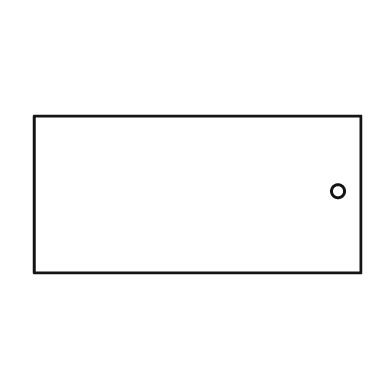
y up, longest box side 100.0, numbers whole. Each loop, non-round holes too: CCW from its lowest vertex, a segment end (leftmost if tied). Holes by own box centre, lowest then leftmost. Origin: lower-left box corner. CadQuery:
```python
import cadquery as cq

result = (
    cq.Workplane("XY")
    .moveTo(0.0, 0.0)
    .lineTo(100.0, 0.0)
    .lineTo(100.0, 48.0)
    .lineTo(0.0, 48.0)
    .close()
    .moveTo(93.0, 25.0)
    .circle(2.0)
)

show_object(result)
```